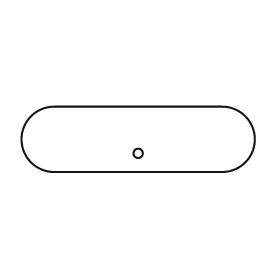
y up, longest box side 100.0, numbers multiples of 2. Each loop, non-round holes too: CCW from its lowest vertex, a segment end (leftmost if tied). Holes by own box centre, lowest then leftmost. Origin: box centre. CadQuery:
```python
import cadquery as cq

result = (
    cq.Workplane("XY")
    .moveTo(-36.0, -14.0)
    .lineTo(36.0, -14.0)
    .threePointArc((50.0, 0.0), (36.0, 14.0))
    .lineTo(-36.0, 14.0)
    .threePointArc((-50.0, 0.0), (-36.0, -14.0))
    .close()
    .moveTo(0.0, -6.0)
    .circle(2.0)
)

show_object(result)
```